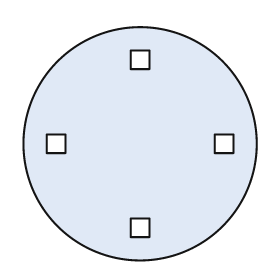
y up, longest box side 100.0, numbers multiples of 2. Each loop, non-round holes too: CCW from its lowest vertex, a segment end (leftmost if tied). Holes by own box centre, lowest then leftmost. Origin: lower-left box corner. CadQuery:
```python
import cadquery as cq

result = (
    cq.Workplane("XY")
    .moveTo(50.0, 50.0)
    .circle(50.0)
    .moveTo(46.0, 10.0)
    .lineTo(54.0, 10.0)
    .lineTo(54.0, 18.0)
    .lineTo(46.0, 18.0)
    .close()
    .moveTo(10.0, 46.0)
    .lineTo(18.0, 46.0)
    .lineTo(18.0, 54.0)
    .lineTo(10.0, 54.0)
    .close()
    .moveTo(82.0, 46.0)
    .lineTo(90.0, 46.0)
    .lineTo(90.0, 54.0)
    .lineTo(82.0, 54.0)
    .close()
    .moveTo(46.0, 82.0)
    .lineTo(54.0, 82.0)
    .lineTo(54.0, 90.0)
    .lineTo(46.0, 90.0)
    .close()
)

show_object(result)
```